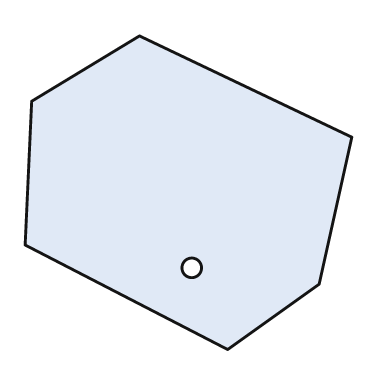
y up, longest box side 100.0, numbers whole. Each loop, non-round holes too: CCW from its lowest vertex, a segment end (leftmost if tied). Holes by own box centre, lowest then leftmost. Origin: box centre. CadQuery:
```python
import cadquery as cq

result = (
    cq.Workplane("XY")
    .moveTo(12.0, -48.0)
    .lineTo(40.0, -28.0)
    .lineTo(50.0, 17.0)
    .lineTo(-15.0, 48.0)
    .lineTo(-48.0, 28.0)
    .lineTo(-50.0, -16.0)
    .close()
    .moveTo(1.0, -23.0)
    .circle(3.0)
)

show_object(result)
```